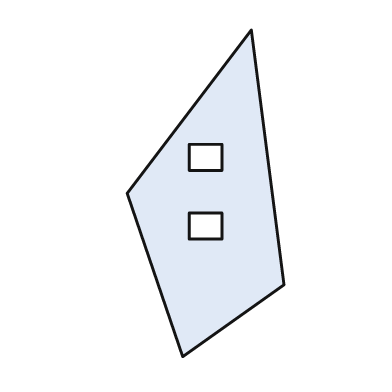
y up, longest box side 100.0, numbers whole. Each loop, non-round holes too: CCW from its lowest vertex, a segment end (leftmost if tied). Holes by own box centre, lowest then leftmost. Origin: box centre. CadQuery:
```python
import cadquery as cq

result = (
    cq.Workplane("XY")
    .moveTo(-7.0, -50.0)
    .lineTo(24.0, -28.0)
    .lineTo(14.0, 50.0)
    .lineTo(-24.0, 0.0)
    .close()
    .moveTo(-5.0, -14.0)
    .lineTo(5.0, -14.0)
    .lineTo(5.0, -6.0)
    .lineTo(-5.0, -6.0)
    .close()
    .moveTo(-5.0, 7.0)
    .lineTo(5.0, 7.0)
    .lineTo(5.0, 15.0)
    .lineTo(-5.0, 15.0)
    .close()
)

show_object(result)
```